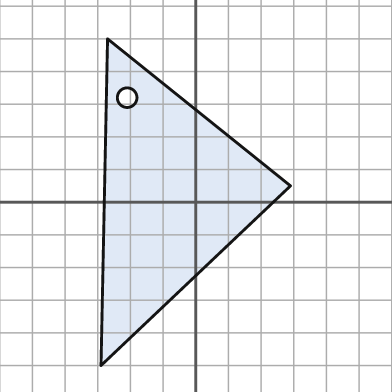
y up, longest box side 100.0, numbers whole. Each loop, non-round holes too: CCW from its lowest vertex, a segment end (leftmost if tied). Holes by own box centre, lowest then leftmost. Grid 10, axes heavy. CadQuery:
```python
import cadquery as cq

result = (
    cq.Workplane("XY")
    .moveTo(-29.0, -50.0)
    .lineTo(29.0, 5.0)
    .lineTo(-27.0, 50.0)
    .close()
    .moveTo(-21.0, 32.0)
    .circle(3.0)
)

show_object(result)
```